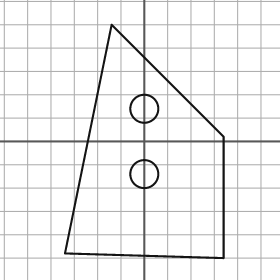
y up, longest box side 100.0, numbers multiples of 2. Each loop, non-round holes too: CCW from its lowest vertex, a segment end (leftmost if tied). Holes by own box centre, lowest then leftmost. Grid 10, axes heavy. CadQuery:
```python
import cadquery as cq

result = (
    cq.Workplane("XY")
    .moveTo(34.0, -50.0)
    .lineTo(34.0, 2.0)
    .lineTo(-14.0, 50.0)
    .lineTo(-34.0, -48.0)
    .close()
    .moveTo(0.0, -14.0)
    .circle(6.0)
    .moveTo(0.0, 14.0)
    .circle(6.0)
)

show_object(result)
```